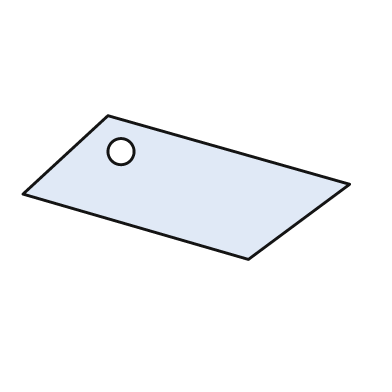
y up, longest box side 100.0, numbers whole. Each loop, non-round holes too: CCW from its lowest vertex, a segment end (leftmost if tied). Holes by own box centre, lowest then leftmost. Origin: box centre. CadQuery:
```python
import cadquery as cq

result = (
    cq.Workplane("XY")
    .moveTo(19.0, -22.0)
    .lineTo(50.0, 1.0)
    .lineTo(-24.0, 22.0)
    .lineTo(-50.0, -2.0)
    .close()
    .moveTo(-20.0, 11.0)
    .circle(4.0)
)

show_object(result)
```